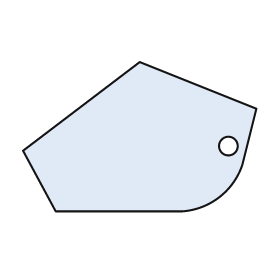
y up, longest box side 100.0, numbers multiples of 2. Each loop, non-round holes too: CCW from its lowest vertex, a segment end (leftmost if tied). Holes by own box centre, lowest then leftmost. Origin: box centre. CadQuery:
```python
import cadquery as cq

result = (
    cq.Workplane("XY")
    .moveTo(-36.0, -32.0)
    .lineTo(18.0, -32.0)
    .threePointArc((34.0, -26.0), (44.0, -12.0))
    .lineTo(50.0, 12.0)
    .lineTo(0.0, 32.0)
    .lineTo(-50.0, -6.0)
    .close()
    .moveTo(38.0, -4.0)
    .circle(4.0)
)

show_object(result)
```